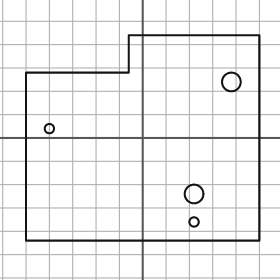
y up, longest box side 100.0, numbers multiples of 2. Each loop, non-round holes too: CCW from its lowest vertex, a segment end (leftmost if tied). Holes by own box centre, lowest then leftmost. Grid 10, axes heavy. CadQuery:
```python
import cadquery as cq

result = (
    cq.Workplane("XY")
    .moveTo(-50.0, -44.0)
    .lineTo(50.0, -44.0)
    .lineTo(50.0, 44.0)
    .lineTo(-6.0, 44.0)
    .lineTo(-6.0, 28.0)
    .lineTo(-50.0, 28.0)
    .close()
    .moveTo(22.0, -36.0)
    .circle(2.0)
    .moveTo(22.0, -24.0)
    .circle(4.0)
    .moveTo(-40.0, 4.0)
    .circle(2.0)
    .moveTo(38.0, 24.0)
    .circle(4.0)
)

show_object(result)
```